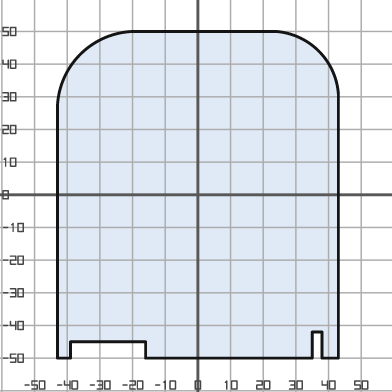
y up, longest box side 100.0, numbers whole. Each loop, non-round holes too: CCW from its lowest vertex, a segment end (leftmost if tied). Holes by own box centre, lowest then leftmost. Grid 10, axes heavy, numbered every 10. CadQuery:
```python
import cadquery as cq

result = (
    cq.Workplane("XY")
    .moveTo(-43.0, -50.0)
    .lineTo(-39.0, -50.0)
    .lineTo(-39.0, -45.0)
    .lineTo(-16.0, -45.0)
    .lineTo(-16.0, -50.0)
    .lineTo(35.0, -50.0)
    .lineTo(35.0, -42.0)
    .lineTo(38.0, -42.0)
    .lineTo(38.0, -50.0)
    .lineTo(43.0, -50.0)
    .lineTo(43.0, 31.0)
    .threePointArc((37.0, 44.0), (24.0, 50.0))
    .lineTo(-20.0, 50.0)
    .threePointArc((-36.0, 43.0), (-43.0, 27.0))
    .close()
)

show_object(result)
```